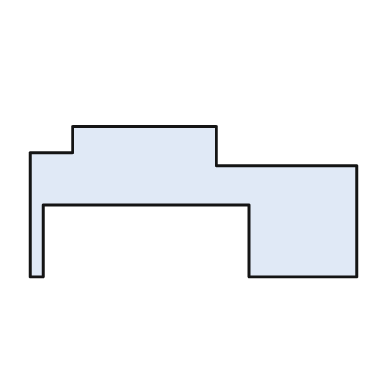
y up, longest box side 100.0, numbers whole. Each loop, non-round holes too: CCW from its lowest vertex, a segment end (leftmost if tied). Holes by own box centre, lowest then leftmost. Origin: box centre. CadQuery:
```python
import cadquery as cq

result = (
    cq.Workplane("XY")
    .moveTo(-50.0, -23.0)
    .lineTo(-46.0, -23.0)
    .lineTo(-46.0, -1.0)
    .lineTo(17.0, -1.0)
    .lineTo(17.0, -23.0)
    .lineTo(50.0, -23.0)
    .lineTo(50.0, 11.0)
    .lineTo(7.0, 11.0)
    .lineTo(7.0, 23.0)
    .lineTo(-37.0, 23.0)
    .lineTo(-37.0, 15.0)
    .lineTo(-50.0, 15.0)
    .close()
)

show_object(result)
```